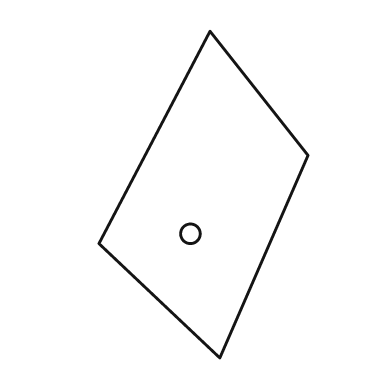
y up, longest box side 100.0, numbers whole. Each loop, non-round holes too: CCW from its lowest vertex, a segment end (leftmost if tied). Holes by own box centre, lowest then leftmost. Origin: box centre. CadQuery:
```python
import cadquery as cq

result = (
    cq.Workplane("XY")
    .moveTo(5.0, -50.0)
    .lineTo(32.0, 12.0)
    .lineTo(2.0, 50.0)
    .lineTo(-32.0, -15.0)
    .close()
    .moveTo(-4.0, -12.0)
    .circle(3.0)
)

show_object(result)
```